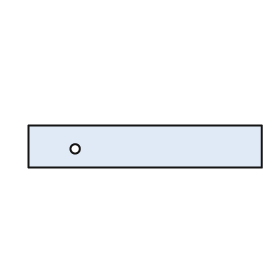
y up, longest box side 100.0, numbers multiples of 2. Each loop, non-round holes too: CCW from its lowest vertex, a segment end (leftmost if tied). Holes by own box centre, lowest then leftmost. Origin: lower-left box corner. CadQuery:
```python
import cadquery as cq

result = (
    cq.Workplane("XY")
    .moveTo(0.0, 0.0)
    .lineTo(100.0, 0.0)
    .lineTo(100.0, 18.0)
    .lineTo(0.0, 18.0)
    .close()
    .moveTo(20.0, 8.0)
    .circle(2.0)
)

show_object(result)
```